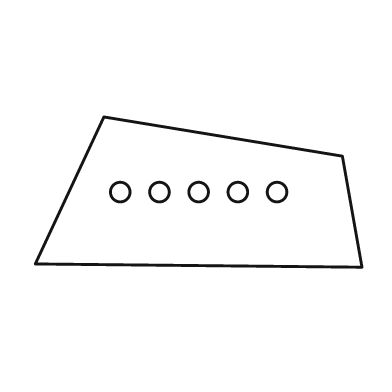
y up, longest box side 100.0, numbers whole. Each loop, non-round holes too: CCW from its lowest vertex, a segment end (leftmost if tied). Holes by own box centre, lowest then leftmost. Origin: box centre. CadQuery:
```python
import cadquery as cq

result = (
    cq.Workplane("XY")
    .moveTo(50.0, -23.0)
    .lineTo(44.0, 11.0)
    .lineTo(-29.0, 23.0)
    .lineTo(-50.0, -22.0)
    .close()
    .moveTo(-24.0, 0.0)
    .circle(3.0)
    .moveTo(-12.0, 0.0)
    .circle(3.0)
    .moveTo(0.0, 0.0)
    .circle(3.0)
    .moveTo(12.0, 0.0)
    .circle(3.0)
    .moveTo(24.0, 0.0)
    .circle(3.0)
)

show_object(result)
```